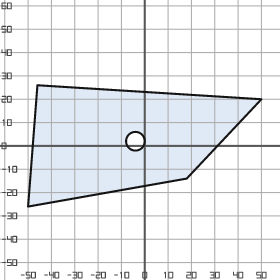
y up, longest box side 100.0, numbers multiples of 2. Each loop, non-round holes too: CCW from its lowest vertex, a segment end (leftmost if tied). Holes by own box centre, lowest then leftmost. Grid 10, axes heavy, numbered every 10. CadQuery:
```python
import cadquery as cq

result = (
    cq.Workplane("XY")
    .moveTo(-50.0, -26.0)
    .lineTo(18.0, -14.0)
    .lineTo(50.0, 20.0)
    .lineTo(-46.0, 26.0)
    .close()
    .moveTo(-4.0, 2.0)
    .circle(4.0)
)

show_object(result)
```